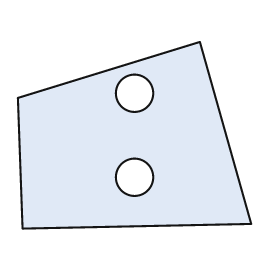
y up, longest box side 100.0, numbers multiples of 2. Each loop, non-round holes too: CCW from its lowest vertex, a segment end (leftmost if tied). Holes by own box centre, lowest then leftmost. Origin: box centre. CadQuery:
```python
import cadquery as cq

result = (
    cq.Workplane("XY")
    .moveTo(-48.0, -40.0)
    .lineTo(50.0, -38.0)
    .lineTo(28.0, 40.0)
    .lineTo(-50.0, 16.0)
    .close()
    .moveTo(0.0, -18.0)
    .circle(8.0)
    .moveTo(0.0, 18.0)
    .circle(8.0)
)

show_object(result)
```